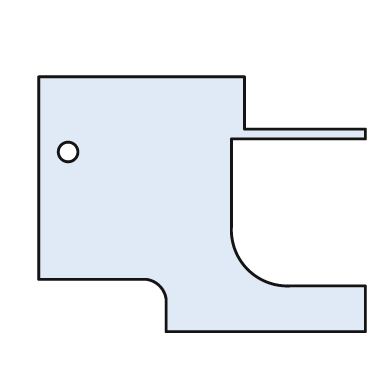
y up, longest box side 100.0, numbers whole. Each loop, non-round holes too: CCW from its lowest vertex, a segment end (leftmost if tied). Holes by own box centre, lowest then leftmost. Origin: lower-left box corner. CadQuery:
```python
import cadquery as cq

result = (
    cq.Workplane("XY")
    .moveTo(39.0, 0.0)
    .lineTo(100.0, 0.0)
    .lineTo(100.0, 14.0)
    .lineTo(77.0, 14.0)
    .threePointArc((64.0, 19.0), (59.0, 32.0))
    .lineTo(59.0, 59.0)
    .lineTo(100.0, 59.0)
    .lineTo(100.0, 62.0)
    .lineTo(63.0, 62.0)
    .lineTo(63.0, 78.0)
    .lineTo(0.0, 78.0)
    .lineTo(0.0, 16.0)
    .lineTo(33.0, 16.0)
    .threePointArc((37.0, 14.0), (39.0, 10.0))
    .close()
    .moveTo(9.0, 55.0)
    .circle(3.0)
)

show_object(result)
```